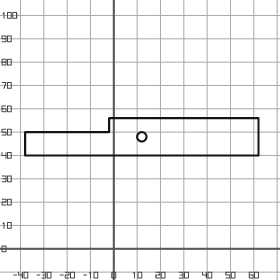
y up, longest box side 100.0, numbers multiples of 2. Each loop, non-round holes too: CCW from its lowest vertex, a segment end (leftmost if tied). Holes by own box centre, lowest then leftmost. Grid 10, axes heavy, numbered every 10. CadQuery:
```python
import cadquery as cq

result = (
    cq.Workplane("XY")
    .moveTo(-38.0, 40.0)
    .lineTo(62.0, 40.0)
    .lineTo(62.0, 56.0)
    .lineTo(-2.0, 56.0)
    .lineTo(-2.0, 50.0)
    .lineTo(-38.0, 50.0)
    .close()
    .moveTo(12.0, 48.0)
    .circle(2.0)
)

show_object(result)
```